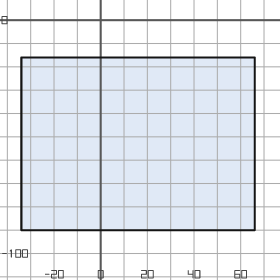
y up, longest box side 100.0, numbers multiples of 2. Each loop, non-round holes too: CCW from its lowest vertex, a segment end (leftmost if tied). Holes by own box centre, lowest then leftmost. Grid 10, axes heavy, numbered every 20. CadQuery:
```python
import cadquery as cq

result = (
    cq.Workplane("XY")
    .moveTo(-34.0, -90.0)
    .lineTo(66.0, -90.0)
    .lineTo(66.0, -16.0)
    .lineTo(-34.0, -16.0)
    .close()
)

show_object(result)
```